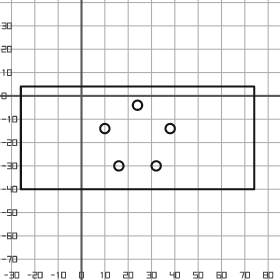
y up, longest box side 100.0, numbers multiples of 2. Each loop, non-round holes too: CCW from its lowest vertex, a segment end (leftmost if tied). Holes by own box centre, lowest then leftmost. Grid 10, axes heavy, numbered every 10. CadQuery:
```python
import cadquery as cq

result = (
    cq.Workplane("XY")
    .moveTo(-26.0, -40.0)
    .lineTo(74.0, -40.0)
    .lineTo(74.0, 4.0)
    .lineTo(-26.0, 4.0)
    .close()
    .moveTo(16.0, -30.0)
    .circle(2.0)
    .moveTo(32.0, -30.0)
    .circle(2.0)
    .moveTo(10.0, -14.0)
    .circle(2.0)
    .moveTo(38.0, -14.0)
    .circle(2.0)
    .moveTo(24.0, -4.0)
    .circle(2.0)
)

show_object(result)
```